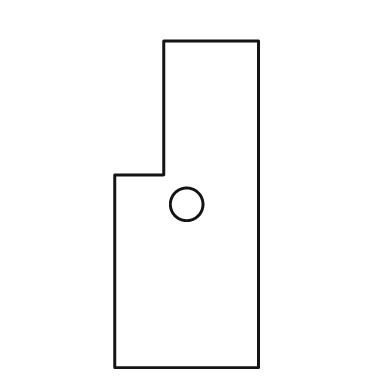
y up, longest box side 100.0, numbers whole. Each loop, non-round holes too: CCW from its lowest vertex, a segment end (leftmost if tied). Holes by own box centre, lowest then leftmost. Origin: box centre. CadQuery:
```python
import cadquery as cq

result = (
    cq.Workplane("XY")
    .moveTo(-22.0, -50.0)
    .lineTo(22.0, -50.0)
    .lineTo(22.0, 50.0)
    .lineTo(-7.0, 50.0)
    .lineTo(-7.0, 9.0)
    .lineTo(-22.0, 9.0)
    .close()
    .moveTo(0.0, 0.0)
    .circle(5.0)
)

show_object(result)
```